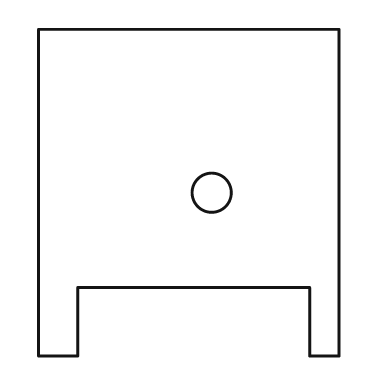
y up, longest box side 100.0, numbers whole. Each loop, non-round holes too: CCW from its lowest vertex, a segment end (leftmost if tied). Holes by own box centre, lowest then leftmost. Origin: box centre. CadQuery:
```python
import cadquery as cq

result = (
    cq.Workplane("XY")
    .moveTo(-46.0, -50.0)
    .lineTo(-34.0, -50.0)
    .lineTo(-34.0, -29.0)
    .lineTo(37.0, -29.0)
    .lineTo(37.0, -50.0)
    .lineTo(46.0, -50.0)
    .lineTo(46.0, 50.0)
    .lineTo(-46.0, 50.0)
    .close()
    .moveTo(7.0, 0.0)
    .circle(6.0)
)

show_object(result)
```